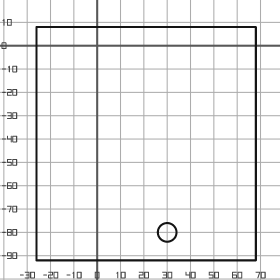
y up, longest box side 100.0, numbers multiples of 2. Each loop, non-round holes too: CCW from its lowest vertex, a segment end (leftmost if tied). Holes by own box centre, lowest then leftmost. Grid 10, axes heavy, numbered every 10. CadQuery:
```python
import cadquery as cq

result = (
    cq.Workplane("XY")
    .moveTo(-26.0, -92.0)
    .lineTo(68.0, -92.0)
    .lineTo(68.0, 8.0)
    .lineTo(-26.0, 8.0)
    .close()
    .moveTo(30.0, -80.0)
    .circle(4.0)
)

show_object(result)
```